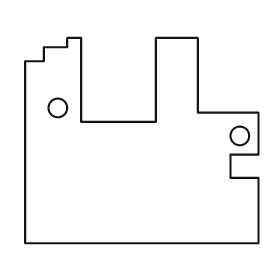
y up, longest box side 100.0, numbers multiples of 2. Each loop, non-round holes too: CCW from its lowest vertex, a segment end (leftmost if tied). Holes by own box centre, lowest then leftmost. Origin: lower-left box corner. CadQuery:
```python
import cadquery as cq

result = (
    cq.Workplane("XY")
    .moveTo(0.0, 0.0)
    .lineTo(100.0, 0.0)
    .lineTo(100.0, 28.0)
    .lineTo(88.0, 28.0)
    .lineTo(88.0, 38.0)
    .lineTo(100.0, 38.0)
    .lineTo(100.0, 56.0)
    .lineTo(74.0, 56.0)
    .lineTo(74.0, 88.0)
    .lineTo(56.0, 88.0)
    .lineTo(56.0, 52.0)
    .lineTo(24.0, 52.0)
    .lineTo(24.0, 88.0)
    .lineTo(18.0, 88.0)
    .lineTo(18.0, 84.0)
    .lineTo(8.0, 84.0)
    .lineTo(8.0, 78.0)
    .lineTo(0.0, 78.0)
    .close()
    .moveTo(92.0, 46.0)
    .circle(4.0)
    .moveTo(14.0, 58.0)
    .circle(4.0)
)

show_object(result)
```